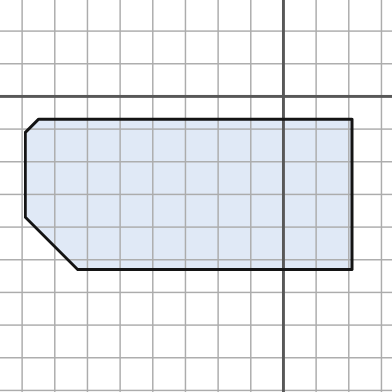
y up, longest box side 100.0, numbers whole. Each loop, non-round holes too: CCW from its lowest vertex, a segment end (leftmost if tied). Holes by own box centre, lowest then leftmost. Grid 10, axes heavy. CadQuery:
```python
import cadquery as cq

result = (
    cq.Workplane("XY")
    .moveTo(-63.0, -53.0)
    .lineTo(21.0, -53.0)
    .lineTo(21.0, -7.0)
    .lineTo(-75.0, -7.0)
    .lineTo(-79.0, -11.0)
    .lineTo(-79.0, -37.0)
    .close()
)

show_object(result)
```